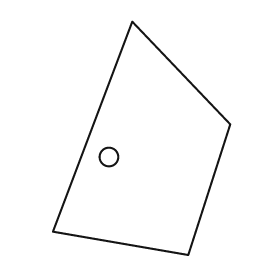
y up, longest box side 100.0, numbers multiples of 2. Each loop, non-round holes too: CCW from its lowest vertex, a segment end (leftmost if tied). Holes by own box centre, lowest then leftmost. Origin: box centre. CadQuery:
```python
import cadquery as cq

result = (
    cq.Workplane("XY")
    .moveTo(20.0, -50.0)
    .lineTo(38.0, 6.0)
    .lineTo(-4.0, 50.0)
    .lineTo(-38.0, -40.0)
    .close()
    .moveTo(-14.0, -8.0)
    .circle(4.0)
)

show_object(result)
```